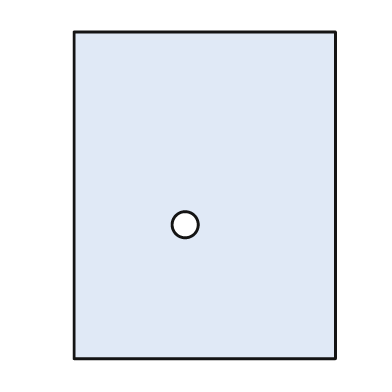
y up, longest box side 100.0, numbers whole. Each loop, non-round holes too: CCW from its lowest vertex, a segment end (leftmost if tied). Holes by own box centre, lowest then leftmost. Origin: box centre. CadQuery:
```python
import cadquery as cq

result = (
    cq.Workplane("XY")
    .moveTo(-40.0, -50.0)
    .lineTo(40.0, -50.0)
    .lineTo(40.0, 50.0)
    .lineTo(-40.0, 50.0)
    .close()
    .moveTo(-6.0, -9.0)
    .circle(4.0)
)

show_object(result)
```